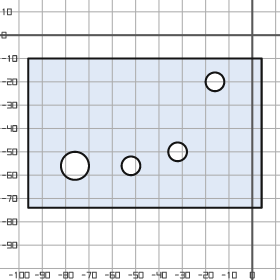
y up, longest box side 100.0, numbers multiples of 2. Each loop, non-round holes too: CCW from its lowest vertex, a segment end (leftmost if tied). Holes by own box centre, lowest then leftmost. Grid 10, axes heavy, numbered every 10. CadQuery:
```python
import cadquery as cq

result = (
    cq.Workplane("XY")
    .moveTo(-96.0, -74.0)
    .lineTo(4.0, -74.0)
    .lineTo(4.0, -10.0)
    .lineTo(-96.0, -10.0)
    .close()
    .moveTo(-76.0, -56.0)
    .circle(6.0)
    .moveTo(-52.0, -56.0)
    .circle(4.0)
    .moveTo(-32.0, -50.0)
    .circle(4.0)
    .moveTo(-16.0, -20.0)
    .circle(4.0)
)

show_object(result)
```